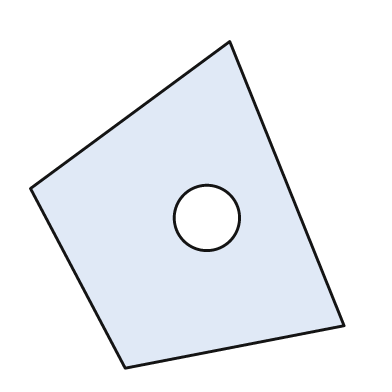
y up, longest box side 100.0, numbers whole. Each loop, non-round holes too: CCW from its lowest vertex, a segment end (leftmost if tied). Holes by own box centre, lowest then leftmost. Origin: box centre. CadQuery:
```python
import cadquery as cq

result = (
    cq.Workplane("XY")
    .moveTo(-19.0, -50.0)
    .lineTo(48.0, -37.0)
    .lineTo(13.0, 50.0)
    .lineTo(-48.0, 5.0)
    .close()
    .moveTo(6.0, -4.0)
    .circle(10.0)
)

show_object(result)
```